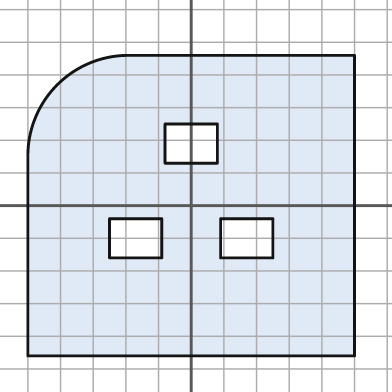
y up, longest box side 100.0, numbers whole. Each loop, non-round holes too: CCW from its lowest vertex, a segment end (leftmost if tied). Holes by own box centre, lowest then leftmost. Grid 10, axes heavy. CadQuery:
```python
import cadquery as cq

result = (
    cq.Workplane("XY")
    .moveTo(-50.0, -46.0)
    .lineTo(50.0, -46.0)
    .lineTo(50.0, 46.0)
    .lineTo(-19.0, 46.0)
    .threePointArc((-41.0, 37.0), (-50.0, 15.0))
    .close()
    .moveTo(-25.0, -16.0)
    .lineTo(-9.0, -16.0)
    .lineTo(-9.0, -4.0)
    .lineTo(-25.0, -4.0)
    .close()
    .moveTo(9.0, -16.0)
    .lineTo(25.0, -16.0)
    .lineTo(25.0, -4.0)
    .lineTo(9.0, -4.0)
    .close()
    .moveTo(-8.0, 13.0)
    .lineTo(8.0, 13.0)
    .lineTo(8.0, 25.0)
    .lineTo(-8.0, 25.0)
    .close()
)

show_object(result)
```